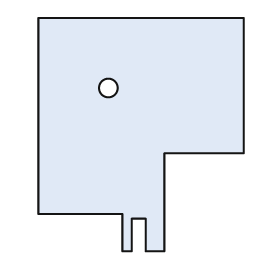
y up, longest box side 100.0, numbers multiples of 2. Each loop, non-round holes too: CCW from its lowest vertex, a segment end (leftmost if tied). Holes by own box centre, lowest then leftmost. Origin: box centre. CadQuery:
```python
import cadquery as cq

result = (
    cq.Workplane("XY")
    .moveTo(-8.0, -50.0)
    .lineTo(-4.0, -50.0)
    .lineTo(-4.0, -36.0)
    .lineTo(2.0, -36.0)
    .lineTo(2.0, -50.0)
    .lineTo(10.0, -50.0)
    .lineTo(10.0, -8.0)
    .lineTo(44.0, -8.0)
    .lineTo(44.0, 50.0)
    .lineTo(-44.0, 50.0)
    .lineTo(-44.0, -34.0)
    .lineTo(-8.0, -34.0)
    .close()
    .moveTo(-14.0, 20.0)
    .circle(4.0)
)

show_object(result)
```